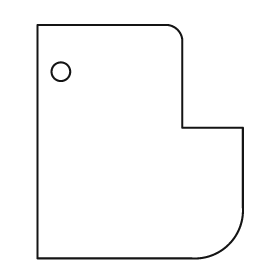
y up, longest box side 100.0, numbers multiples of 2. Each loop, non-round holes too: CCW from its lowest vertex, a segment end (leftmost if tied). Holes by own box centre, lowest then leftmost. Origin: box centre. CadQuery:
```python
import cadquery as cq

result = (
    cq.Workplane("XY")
    .moveTo(-44.0, -50.0)
    .lineTo(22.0, -50.0)
    .threePointArc((38.0, -44.0), (44.0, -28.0))
    .lineTo(44.0, 6.0)
    .lineTo(18.0, 6.0)
    .lineTo(18.0, 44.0)
    .threePointArc((16.0, 48.0), (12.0, 50.0))
    .lineTo(-44.0, 50.0)
    .close()
    .moveTo(-34.0, 30.0)
    .circle(4.0)
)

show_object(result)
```